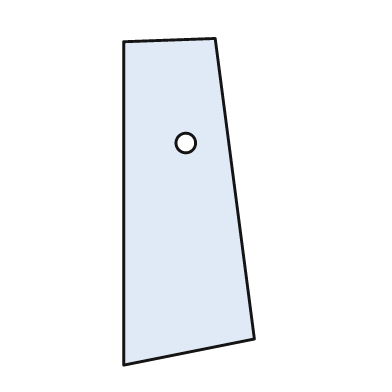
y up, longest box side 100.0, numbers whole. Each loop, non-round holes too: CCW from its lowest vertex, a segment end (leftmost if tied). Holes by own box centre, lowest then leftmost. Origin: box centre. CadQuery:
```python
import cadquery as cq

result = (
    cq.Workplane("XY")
    .moveTo(-20.0, -50.0)
    .lineTo(20.0, -42.0)
    .lineTo(8.0, 50.0)
    .lineTo(-20.0, 49.0)
    .close()
    .moveTo(-1.0, 18.0)
    .circle(3.0)
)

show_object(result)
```